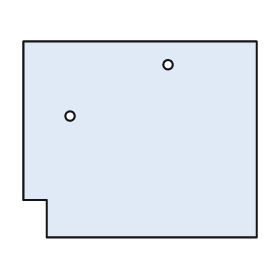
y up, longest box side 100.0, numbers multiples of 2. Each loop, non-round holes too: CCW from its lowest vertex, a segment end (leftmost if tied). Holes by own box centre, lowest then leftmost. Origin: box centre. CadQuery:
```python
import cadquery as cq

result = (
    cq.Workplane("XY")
    .moveTo(-40.0, -42.0)
    .lineTo(50.0, -42.0)
    .lineTo(50.0, 42.0)
    .lineTo(-50.0, 42.0)
    .lineTo(-50.0, -26.0)
    .lineTo(-40.0, -26.0)
    .close()
    .moveTo(-30.0, 10.0)
    .circle(2.0)
    .moveTo(12.0, 32.0)
    .circle(2.0)
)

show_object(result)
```